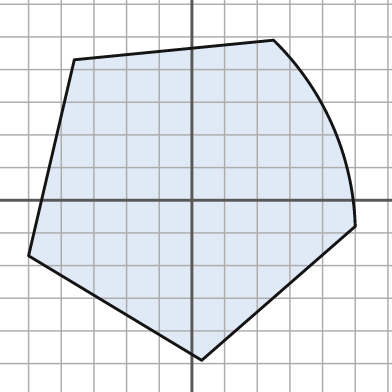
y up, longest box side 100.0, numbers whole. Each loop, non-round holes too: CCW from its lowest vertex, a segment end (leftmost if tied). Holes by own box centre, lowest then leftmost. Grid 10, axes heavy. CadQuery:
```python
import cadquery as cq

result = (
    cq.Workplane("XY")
    .moveTo(3.0, -49.0)
    .lineTo(50.0, -8.0)
    .threePointArc((43.0, 23.0), (25.0, 49.0))
    .lineTo(-36.0, 43.0)
    .lineTo(-50.0, -17.0)
    .close()
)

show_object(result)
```